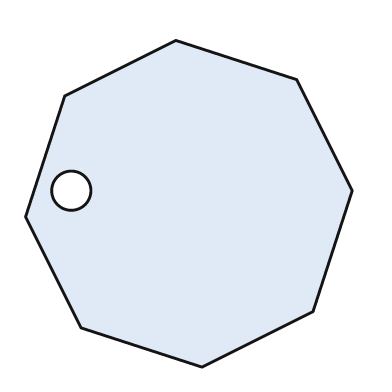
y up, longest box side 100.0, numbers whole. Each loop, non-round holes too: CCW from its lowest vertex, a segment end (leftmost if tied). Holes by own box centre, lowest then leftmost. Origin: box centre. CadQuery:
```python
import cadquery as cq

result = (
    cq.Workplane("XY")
    .moveTo(4.0, -50.0)
    .lineTo(38.0, -33.0)
    .lineTo(50.0, 4.0)
    .lineTo(33.0, 38.0)
    .lineTo(-4.0, 50.0)
    .lineTo(-38.0, 33.0)
    .lineTo(-50.0, -4.0)
    .lineTo(-33.0, -38.0)
    .close()
    .moveTo(-36.0, 4.0)
    .circle(6.0)
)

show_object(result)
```